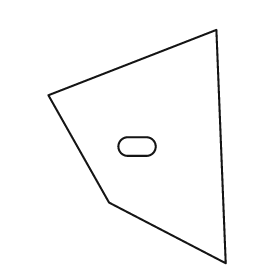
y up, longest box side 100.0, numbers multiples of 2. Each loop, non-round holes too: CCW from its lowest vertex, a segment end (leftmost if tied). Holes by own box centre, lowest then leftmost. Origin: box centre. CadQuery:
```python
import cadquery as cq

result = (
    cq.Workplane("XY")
    .moveTo(38.0, -50.0)
    .lineTo(34.0, 50.0)
    .lineTo(-38.0, 22.0)
    .lineTo(-12.0, -24.0)
    .close()
    .moveTo(-4.0, -4.0)
    .lineTo(4.0, -4.0)
    .threePointArc((8.0, 0.0), (4.0, 4.0))
    .lineTo(-4.0, 4.0)
    .threePointArc((-8.0, 0.0), (-4.0, -4.0))
    .close()
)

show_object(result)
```